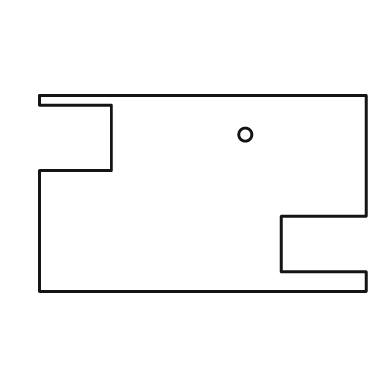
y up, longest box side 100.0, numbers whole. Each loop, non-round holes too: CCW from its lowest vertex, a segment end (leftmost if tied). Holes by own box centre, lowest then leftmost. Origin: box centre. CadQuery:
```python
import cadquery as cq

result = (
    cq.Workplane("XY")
    .moveTo(-50.0, -30.0)
    .lineTo(50.0, -30.0)
    .lineTo(50.0, -24.0)
    .lineTo(24.0, -24.0)
    .lineTo(24.0, -7.0)
    .lineTo(50.0, -7.0)
    .lineTo(50.0, 30.0)
    .lineTo(-50.0, 30.0)
    .lineTo(-50.0, 27.0)
    .lineTo(-28.0, 27.0)
    .lineTo(-28.0, 7.0)
    .lineTo(-50.0, 7.0)
    .close()
    .moveTo(13.0, 18.0)
    .circle(2.0)
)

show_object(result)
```